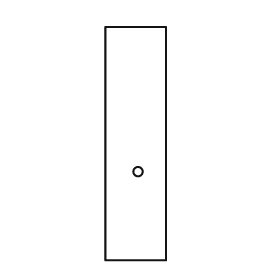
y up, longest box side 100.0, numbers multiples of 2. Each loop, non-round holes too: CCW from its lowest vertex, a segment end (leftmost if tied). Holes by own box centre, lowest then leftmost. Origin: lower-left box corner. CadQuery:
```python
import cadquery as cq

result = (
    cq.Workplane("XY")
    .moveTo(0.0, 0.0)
    .lineTo(26.0, 0.0)
    .lineTo(26.0, 100.0)
    .lineTo(0.0, 100.0)
    .close()
    .moveTo(14.0, 38.0)
    .circle(2.0)
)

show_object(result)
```